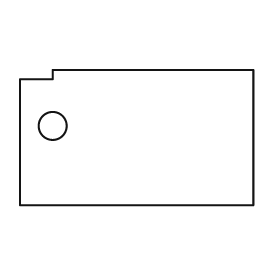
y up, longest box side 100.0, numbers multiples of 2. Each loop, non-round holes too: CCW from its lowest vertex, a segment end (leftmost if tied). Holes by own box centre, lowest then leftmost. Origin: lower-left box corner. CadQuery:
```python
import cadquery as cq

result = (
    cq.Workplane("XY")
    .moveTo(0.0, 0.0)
    .lineTo(100.0, 0.0)
    .lineTo(100.0, 58.0)
    .lineTo(14.0, 58.0)
    .lineTo(14.0, 54.0)
    .lineTo(0.0, 54.0)
    .close()
    .moveTo(14.0, 34.0)
    .circle(6.0)
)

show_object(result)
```